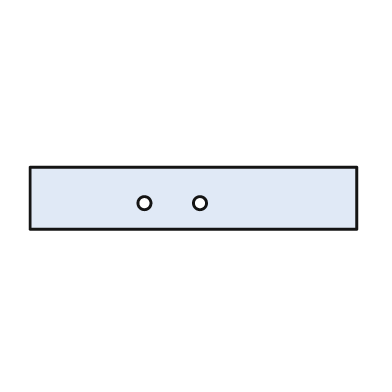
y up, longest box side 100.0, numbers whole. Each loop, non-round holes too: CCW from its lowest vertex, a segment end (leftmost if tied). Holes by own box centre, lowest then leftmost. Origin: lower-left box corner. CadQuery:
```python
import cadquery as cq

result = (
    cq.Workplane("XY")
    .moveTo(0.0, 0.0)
    .lineTo(100.0, 0.0)
    .lineTo(100.0, 19.0)
    .lineTo(0.0, 19.0)
    .close()
    .moveTo(35.0, 8.0)
    .circle(2.0)
    .moveTo(52.0, 8.0)
    .circle(2.0)
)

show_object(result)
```